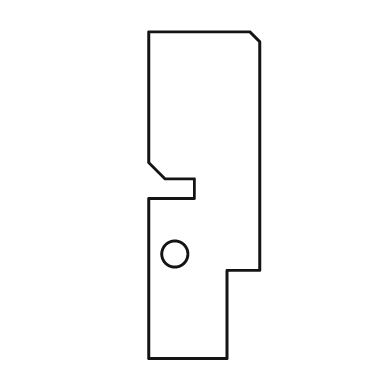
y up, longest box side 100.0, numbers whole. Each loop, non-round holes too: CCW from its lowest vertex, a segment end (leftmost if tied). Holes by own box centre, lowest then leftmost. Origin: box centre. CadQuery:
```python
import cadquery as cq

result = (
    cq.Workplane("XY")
    .moveTo(-17.0, -50.0)
    .lineTo(7.0, -50.0)
    .lineTo(7.0, -23.0)
    .lineTo(17.0, -23.0)
    .lineTo(17.0, 47.0)
    .lineTo(14.0, 50.0)
    .lineTo(-17.0, 50.0)
    .lineTo(-17.0, 10.0)
    .lineTo(-12.0, 5.0)
    .lineTo(-3.0, 5.0)
    .lineTo(-3.0, -1.0)
    .lineTo(-17.0, -1.0)
    .close()
    .moveTo(-9.0, -18.0)
    .circle(4.0)
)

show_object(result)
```